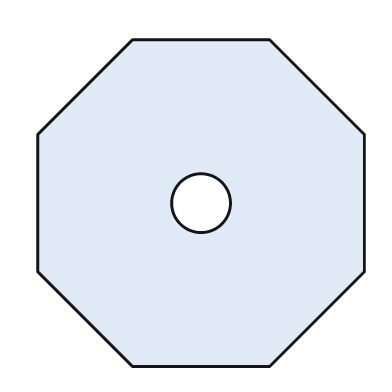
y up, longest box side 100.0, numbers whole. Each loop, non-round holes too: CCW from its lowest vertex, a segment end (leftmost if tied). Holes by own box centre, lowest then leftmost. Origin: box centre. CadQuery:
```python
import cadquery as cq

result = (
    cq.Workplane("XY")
    .moveTo(-21.0, -50.0)
    .lineTo(21.0, -50.0)
    .lineTo(50.0, -21.0)
    .lineTo(50.0, 21.0)
    .lineTo(21.0, 50.0)
    .lineTo(-21.0, 50.0)
    .lineTo(-50.0, 21.0)
    .lineTo(-50.0, -21.0)
    .close()
    .moveTo(0.0, 0.0)
    .circle(9.0)
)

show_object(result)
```